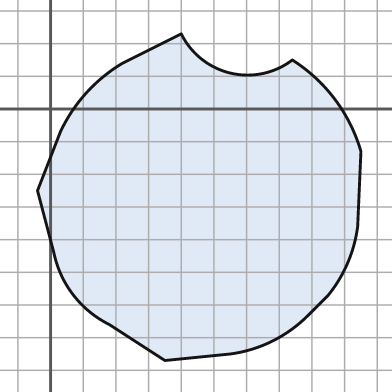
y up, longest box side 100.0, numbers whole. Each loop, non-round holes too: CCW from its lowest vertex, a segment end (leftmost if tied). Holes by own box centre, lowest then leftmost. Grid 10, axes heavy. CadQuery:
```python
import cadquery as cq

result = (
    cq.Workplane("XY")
    .moveTo(35.0, -77.0)
    .lineTo(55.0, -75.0)
    .threePointArc((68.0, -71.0), (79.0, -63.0))
    .lineTo(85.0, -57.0)
    .threePointArc((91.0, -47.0), (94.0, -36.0))
    .lineTo(95.0, -13.0)
    .threePointArc((87.0, 3.0), (74.0, 15.0))
    .threePointArc((55.0, 11.0), (40.0, 23.0))
    .lineTo(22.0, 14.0)
    .threePointArc((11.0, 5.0), (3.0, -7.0))
    .lineTo(-4.0, -25.0)
    .lineTo(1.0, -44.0)
    .threePointArc((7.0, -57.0), (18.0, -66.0))
    .close()
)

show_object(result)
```